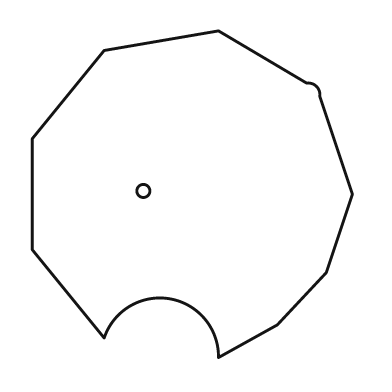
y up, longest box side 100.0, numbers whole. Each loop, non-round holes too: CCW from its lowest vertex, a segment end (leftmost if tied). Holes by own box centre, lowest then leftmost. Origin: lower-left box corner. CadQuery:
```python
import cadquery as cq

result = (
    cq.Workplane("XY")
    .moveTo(57.0, 0.0)
    .lineTo(75.0, 10.0)
    .lineTo(90.0, 26.0)
    .lineTo(98.0, 50.0)
    .lineTo(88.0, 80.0)
    .threePointArc((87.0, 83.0), (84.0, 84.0))
    .lineTo(57.0, 100.0)
    .lineTo(22.0, 94.0)
    .lineTo(0.0, 67.0)
    .lineTo(0.0, 33.0)
    .lineTo(22.0, 6.0)
    .threePointArc((42.0, 18.0), (57.0, 0.0))
    .close()
    .moveTo(34.0, 51.0)
    .circle(2.0)
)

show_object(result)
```